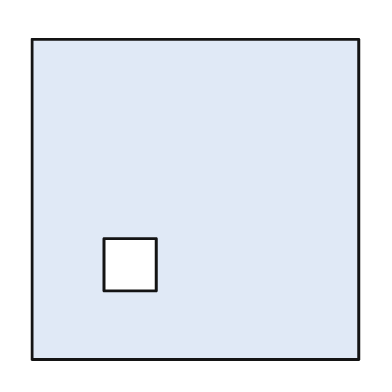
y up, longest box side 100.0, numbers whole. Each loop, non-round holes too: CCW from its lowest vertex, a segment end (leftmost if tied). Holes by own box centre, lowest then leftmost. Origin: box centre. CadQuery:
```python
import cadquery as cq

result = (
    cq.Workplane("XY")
    .moveTo(-50.0, -49.0)
    .lineTo(50.0, -49.0)
    .lineTo(50.0, 49.0)
    .lineTo(-50.0, 49.0)
    .close()
    .moveTo(-28.0, -28.0)
    .lineTo(-12.0, -28.0)
    .lineTo(-12.0, -12.0)
    .lineTo(-28.0, -12.0)
    .close()
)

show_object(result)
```